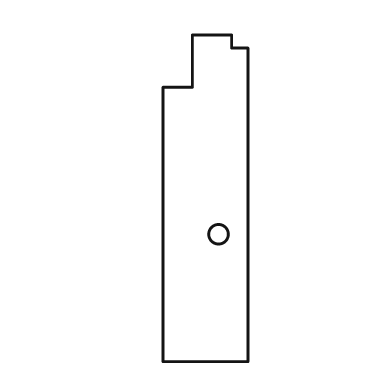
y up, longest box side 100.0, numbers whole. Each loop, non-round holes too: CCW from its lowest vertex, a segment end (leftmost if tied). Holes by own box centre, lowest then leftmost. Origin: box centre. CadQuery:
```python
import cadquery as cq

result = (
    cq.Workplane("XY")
    .moveTo(-13.0, -50.0)
    .lineTo(13.0, -50.0)
    .lineTo(13.0, 46.0)
    .lineTo(8.0, 46.0)
    .lineTo(8.0, 50.0)
    .lineTo(-4.0, 50.0)
    .lineTo(-4.0, 34.0)
    .lineTo(-13.0, 34.0)
    .close()
    .moveTo(4.0, -11.0)
    .circle(3.0)
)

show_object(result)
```